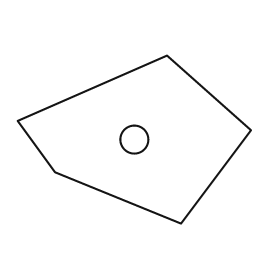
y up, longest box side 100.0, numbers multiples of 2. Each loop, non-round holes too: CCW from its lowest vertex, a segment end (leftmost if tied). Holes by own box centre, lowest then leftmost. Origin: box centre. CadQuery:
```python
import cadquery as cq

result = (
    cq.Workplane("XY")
    .moveTo(20.0, -36.0)
    .lineTo(50.0, 4.0)
    .lineTo(14.0, 36.0)
    .lineTo(-50.0, 8.0)
    .lineTo(-34.0, -14.0)
    .close()
    .moveTo(0.0, 0.0)
    .circle(6.0)
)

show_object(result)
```